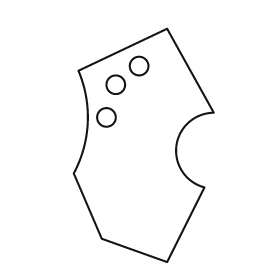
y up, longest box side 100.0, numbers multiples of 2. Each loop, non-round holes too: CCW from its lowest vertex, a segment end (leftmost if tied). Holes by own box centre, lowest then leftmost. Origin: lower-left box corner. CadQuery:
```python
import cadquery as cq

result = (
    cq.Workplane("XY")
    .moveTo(40.0, 0.0)
    .lineTo(56.0, 32.0)
    .threePointArc((44.0, 50.0), (60.0, 64.0))
    .lineTo(40.0, 100.0)
    .lineTo(2.0, 82.0)
    .threePointArc((6.0, 60.0), (0.0, 38.0))
    .lineTo(12.0, 10.0)
    .close()
    .moveTo(14.0, 62.0)
    .circle(4.0)
    .moveTo(18.0, 76.0)
    .circle(4.0)
    .moveTo(28.0, 84.0)
    .circle(4.0)
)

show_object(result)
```